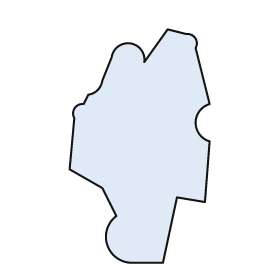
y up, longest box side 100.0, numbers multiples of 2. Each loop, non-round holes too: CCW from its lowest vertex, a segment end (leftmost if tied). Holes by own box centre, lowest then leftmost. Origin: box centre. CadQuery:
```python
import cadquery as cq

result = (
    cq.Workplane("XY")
    .moveTo(-4.0, -50.0)
    .lineTo(10.0, -50.0)
    .lineTo(16.0, -22.0)
    .lineTo(28.0, -24.0)
    .lineTo(30.0, 2.0)
    .threePointArc((24.0, 10.0), (30.0, 18.0))
    .lineTo(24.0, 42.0)
    .threePointArc((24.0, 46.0), (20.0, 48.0))
    .lineTo(12.0, 50.0)
    .lineTo(2.0, 36.0)
    .threePointArc((-4.0, 44.0), (-12.0, 38.0))
    .lineTo(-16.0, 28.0)
    .threePointArc((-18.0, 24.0), (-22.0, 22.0))
    .lineTo(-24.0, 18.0)
    .threePointArc((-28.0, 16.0), (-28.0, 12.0))
    .lineTo(-30.0, -10.0)
    .lineTo(-16.0, -18.0)
    .lineTo(-10.0, -30.0)
    .threePointArc((-14.0, -42.0), (-4.0, -50.0))
    .close()
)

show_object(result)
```